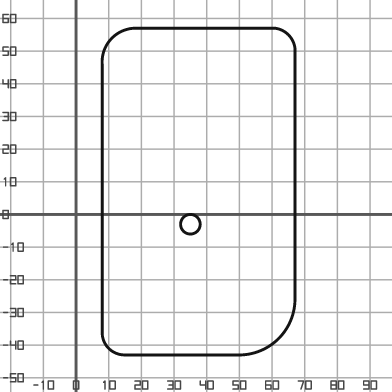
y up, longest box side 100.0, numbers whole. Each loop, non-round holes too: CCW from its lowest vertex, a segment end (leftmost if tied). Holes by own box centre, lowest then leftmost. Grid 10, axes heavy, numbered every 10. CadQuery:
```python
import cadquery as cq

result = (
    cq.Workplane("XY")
    .moveTo(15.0, -43.0)
    .lineTo(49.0, -43.0)
    .threePointArc((62.0, -38.0), (67.0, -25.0))
    .lineTo(67.0, 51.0)
    .threePointArc((65.0, 55.0), (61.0, 57.0))
    .lineTo(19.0, 57.0)
    .threePointArc((11.0, 54.0), (8.0, 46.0))
    .lineTo(8.0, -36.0)
    .threePointArc((10.0, -41.0), (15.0, -43.0))
    .close()
    .moveTo(35.0, -3.0)
    .circle(3.0)
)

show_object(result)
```